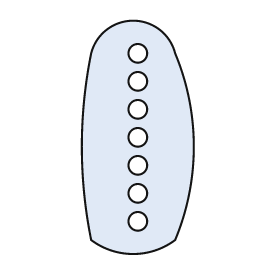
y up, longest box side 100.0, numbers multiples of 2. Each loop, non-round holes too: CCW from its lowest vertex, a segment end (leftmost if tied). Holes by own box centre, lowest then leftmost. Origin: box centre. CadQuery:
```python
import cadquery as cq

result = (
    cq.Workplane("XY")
    .moveTo(-20.0, -44.0)
    .threePointArc((-2.0, -50.0), (16.0, -44.0))
    .threePointArc((24.0, -4.0), (16.0, 36.0))
    .threePointArc((-2.0, 50.0), (-20.0, 36.0))
    .threePointArc((-24.0, -4.0), (-20.0, -44.0))
    .close()
    .moveTo(0.0, -36.0)
    .circle(4.0)
    .moveTo(0.0, -24.0)
    .circle(4.0)
    .moveTo(0.0, -12.0)
    .circle(4.0)
    .moveTo(0.0, 0.0)
    .circle(4.0)
    .moveTo(0.0, 12.0)
    .circle(4.0)
    .moveTo(0.0, 24.0)
    .circle(4.0)
    .moveTo(0.0, 36.0)
    .circle(4.0)
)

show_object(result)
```